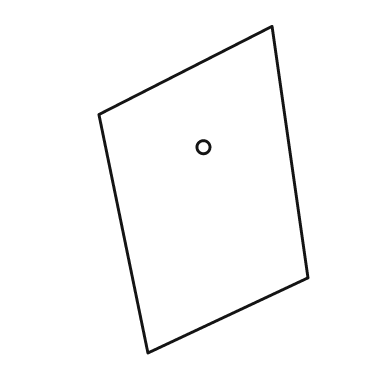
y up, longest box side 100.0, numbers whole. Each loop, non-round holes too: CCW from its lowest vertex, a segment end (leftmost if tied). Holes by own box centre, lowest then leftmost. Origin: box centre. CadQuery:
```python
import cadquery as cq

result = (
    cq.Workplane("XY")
    .moveTo(-17.0, -50.0)
    .lineTo(32.0, -27.0)
    .lineTo(21.0, 50.0)
    .lineTo(-32.0, 23.0)
    .close()
    .moveTo(0.0, 13.0)
    .circle(2.0)
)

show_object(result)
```